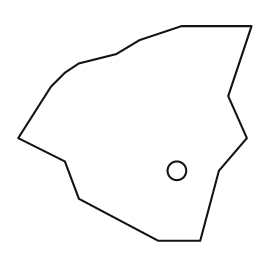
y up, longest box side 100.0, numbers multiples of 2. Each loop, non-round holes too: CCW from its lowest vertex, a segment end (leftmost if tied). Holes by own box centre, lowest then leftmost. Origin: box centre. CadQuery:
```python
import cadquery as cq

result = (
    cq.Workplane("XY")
    .moveTo(10.0, -46.0)
    .lineTo(28.0, -46.0)
    .lineTo(36.0, -16.0)
    .lineTo(48.0, -2.0)
    .lineTo(40.0, 16.0)
    .lineTo(50.0, 46.0)
    .lineTo(20.0, 46.0)
    .lineTo(2.0, 40.0)
    .lineTo(-8.0, 34.0)
    .lineTo(-24.0, 30.0)
    .lineTo(-30.0, 26.0)
    .lineTo(-36.0, 20.0)
    .lineTo(-50.0, -2.0)
    .lineTo(-30.0, -12.0)
    .lineTo(-24.0, -28.0)
    .close()
    .moveTo(18.0, -16.0)
    .circle(4.0)
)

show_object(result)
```